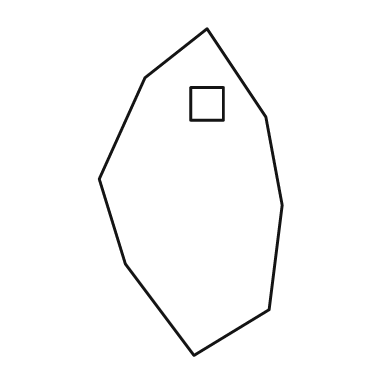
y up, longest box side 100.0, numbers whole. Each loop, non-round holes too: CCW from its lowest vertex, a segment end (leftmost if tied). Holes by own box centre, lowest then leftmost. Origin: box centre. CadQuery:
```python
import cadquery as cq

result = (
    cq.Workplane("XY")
    .moveTo(1.0, -50.0)
    .lineTo(24.0, -36.0)
    .lineTo(28.0, -4.0)
    .lineTo(23.0, 23.0)
    .lineTo(5.0, 50.0)
    .lineTo(-14.0, 35.0)
    .lineTo(-28.0, 4.0)
    .lineTo(-20.0, -22.0)
    .close()
    .moveTo(0.0, 22.0)
    .lineTo(10.0, 22.0)
    .lineTo(10.0, 32.0)
    .lineTo(0.0, 32.0)
    .close()
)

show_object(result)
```